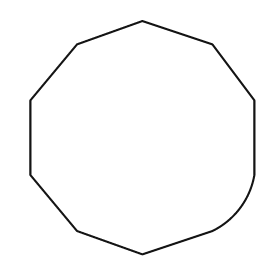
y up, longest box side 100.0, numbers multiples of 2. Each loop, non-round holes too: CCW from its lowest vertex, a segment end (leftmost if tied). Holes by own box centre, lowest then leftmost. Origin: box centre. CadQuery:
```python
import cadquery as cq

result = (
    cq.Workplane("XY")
    .moveTo(0.0, -50.0)
    .lineTo(30.0, -40.0)
    .threePointArc((42.0, -30.0), (48.0, -16.0))
    .lineTo(48.0, 16.0)
    .lineTo(30.0, 40.0)
    .lineTo(0.0, 50.0)
    .lineTo(-28.0, 40.0)
    .lineTo(-48.0, 16.0)
    .lineTo(-48.0, -16.0)
    .lineTo(-28.0, -40.0)
    .close()
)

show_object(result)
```